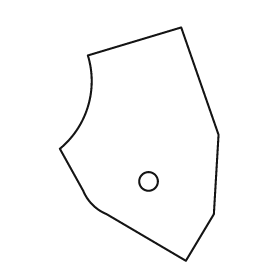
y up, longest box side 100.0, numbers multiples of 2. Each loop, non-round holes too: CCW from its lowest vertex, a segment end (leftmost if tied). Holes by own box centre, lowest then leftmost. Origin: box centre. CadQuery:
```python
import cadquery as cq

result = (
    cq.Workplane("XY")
    .moveTo(20.0, -50.0)
    .lineTo(32.0, -30.0)
    .lineTo(34.0, 4.0)
    .lineTo(18.0, 50.0)
    .lineTo(-22.0, 38.0)
    .threePointArc((-22.0, 16.0), (-34.0, -2.0))
    .lineTo(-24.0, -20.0)
    .threePointArc((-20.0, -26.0), (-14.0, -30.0))
    .close()
    .moveTo(4.0, -16.0)
    .circle(4.0)
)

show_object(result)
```